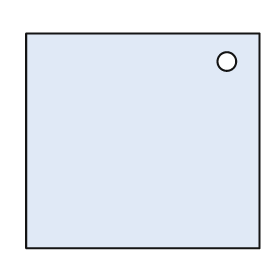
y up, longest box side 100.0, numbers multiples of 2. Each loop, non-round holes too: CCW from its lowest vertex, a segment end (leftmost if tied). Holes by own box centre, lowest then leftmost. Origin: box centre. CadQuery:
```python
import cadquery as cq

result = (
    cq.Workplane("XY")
    .moveTo(-50.0, -46.0)
    .lineTo(50.0, -46.0)
    .lineTo(50.0, 46.0)
    .lineTo(-50.0, 46.0)
    .close()
    .moveTo(36.0, 34.0)
    .circle(4.0)
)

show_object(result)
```